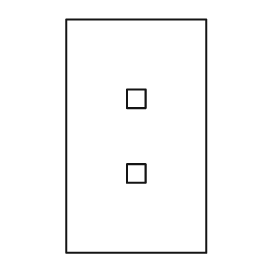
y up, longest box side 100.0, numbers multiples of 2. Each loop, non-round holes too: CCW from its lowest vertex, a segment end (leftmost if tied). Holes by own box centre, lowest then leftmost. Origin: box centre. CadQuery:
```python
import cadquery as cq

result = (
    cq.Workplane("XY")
    .moveTo(-30.0, -50.0)
    .lineTo(30.0, -50.0)
    .lineTo(30.0, 50.0)
    .lineTo(-30.0, 50.0)
    .close()
    .moveTo(-4.0, -20.0)
    .lineTo(4.0, -20.0)
    .lineTo(4.0, -12.0)
    .lineTo(-4.0, -12.0)
    .close()
    .moveTo(-4.0, 12.0)
    .lineTo(4.0, 12.0)
    .lineTo(4.0, 20.0)
    .lineTo(-4.0, 20.0)
    .close()
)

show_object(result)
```